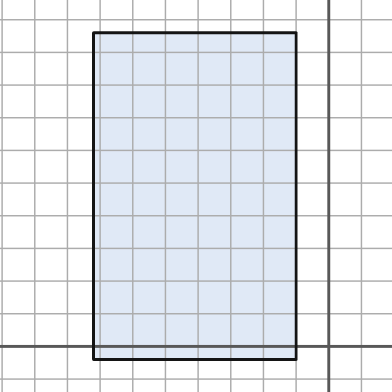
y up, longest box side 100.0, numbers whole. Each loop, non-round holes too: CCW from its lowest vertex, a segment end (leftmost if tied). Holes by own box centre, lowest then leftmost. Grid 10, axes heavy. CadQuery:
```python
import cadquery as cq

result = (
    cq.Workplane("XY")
    .moveTo(-72.0, -4.0)
    .lineTo(-10.0, -4.0)
    .lineTo(-10.0, 96.0)
    .lineTo(-72.0, 96.0)
    .close()
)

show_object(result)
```